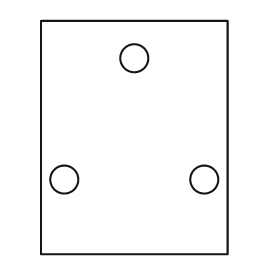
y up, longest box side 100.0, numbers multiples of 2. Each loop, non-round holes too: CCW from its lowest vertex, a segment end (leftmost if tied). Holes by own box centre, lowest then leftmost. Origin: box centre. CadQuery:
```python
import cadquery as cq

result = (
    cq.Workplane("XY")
    .moveTo(-40.0, -50.0)
    .lineTo(40.0, -50.0)
    .lineTo(40.0, 50.0)
    .lineTo(-40.0, 50.0)
    .close()
    .moveTo(-30.0, -18.0)
    .circle(6.0)
    .moveTo(30.0, -18.0)
    .circle(6.0)
    .moveTo(0.0, 34.0)
    .circle(6.0)
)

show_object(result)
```